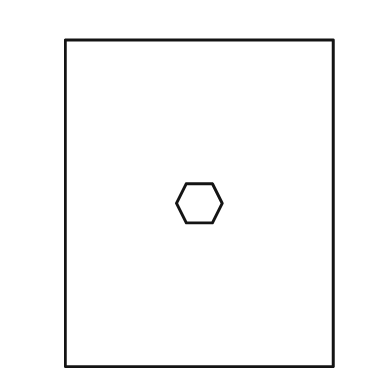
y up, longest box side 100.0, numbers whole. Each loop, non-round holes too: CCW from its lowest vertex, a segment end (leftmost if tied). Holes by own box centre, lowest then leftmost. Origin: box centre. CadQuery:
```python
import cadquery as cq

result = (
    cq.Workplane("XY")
    .moveTo(-41.0, -50.0)
    .lineTo(41.0, -50.0)
    .lineTo(41.0, 50.0)
    .lineTo(-41.0, 50.0)
    .close()
    .moveTo(-4.0, -6.0)
    .lineTo(4.0, -6.0)
    .lineTo(7.0, 0.0)
    .lineTo(4.0, 6.0)
    .lineTo(-4.0, 6.0)
    .lineTo(-7.0, 0.0)
    .close()
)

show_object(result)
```